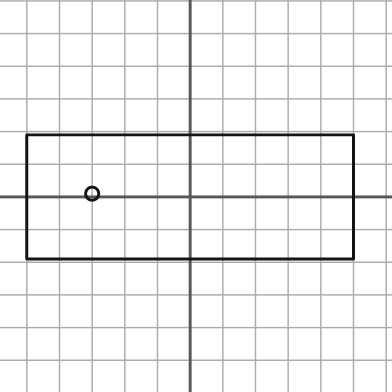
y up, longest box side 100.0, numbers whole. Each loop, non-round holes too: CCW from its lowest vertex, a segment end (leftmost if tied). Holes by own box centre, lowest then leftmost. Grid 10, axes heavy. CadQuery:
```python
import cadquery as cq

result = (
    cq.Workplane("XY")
    .moveTo(-50.0, -19.0)
    .lineTo(50.0, -19.0)
    .lineTo(50.0, 19.0)
    .lineTo(-50.0, 19.0)
    .close()
    .moveTo(-30.0, 1.0)
    .circle(2.0)
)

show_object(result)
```